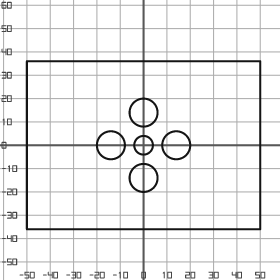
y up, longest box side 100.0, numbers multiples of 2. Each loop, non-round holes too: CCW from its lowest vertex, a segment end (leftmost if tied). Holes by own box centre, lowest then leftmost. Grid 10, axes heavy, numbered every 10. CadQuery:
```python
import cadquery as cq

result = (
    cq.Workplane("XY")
    .moveTo(-50.0, -36.0)
    .lineTo(50.0, -36.0)
    .lineTo(50.0, 36.0)
    .lineTo(-50.0, 36.0)
    .close()
    .moveTo(0.0, -14.0)
    .circle(6.0)
    .moveTo(-14.0, 0.0)
    .circle(6.0)
    .moveTo(0.0, 0.0)
    .circle(4.0)
    .moveTo(14.0, 0.0)
    .circle(6.0)
    .moveTo(0.0, 14.0)
    .circle(6.0)
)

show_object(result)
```